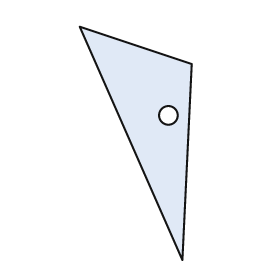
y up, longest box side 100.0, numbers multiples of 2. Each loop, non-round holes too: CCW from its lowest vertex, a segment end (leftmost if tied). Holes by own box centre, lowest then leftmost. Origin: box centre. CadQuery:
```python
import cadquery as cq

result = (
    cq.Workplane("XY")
    .moveTo(20.0, -50.0)
    .lineTo(24.0, 34.0)
    .lineTo(-24.0, 50.0)
    .close()
    .moveTo(14.0, 12.0)
    .circle(4.0)
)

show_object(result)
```